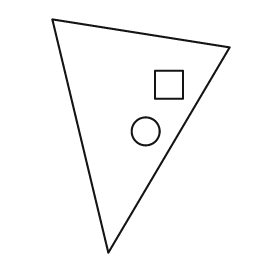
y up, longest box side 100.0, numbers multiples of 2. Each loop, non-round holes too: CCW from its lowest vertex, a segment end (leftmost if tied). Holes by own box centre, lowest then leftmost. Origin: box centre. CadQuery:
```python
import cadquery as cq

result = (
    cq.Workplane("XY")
    .moveTo(-14.0, -50.0)
    .lineTo(38.0, 38.0)
    .lineTo(-38.0, 50.0)
    .close()
    .moveTo(2.0, 2.0)
    .circle(6.0)
    .moveTo(6.0, 16.0)
    .lineTo(18.0, 16.0)
    .lineTo(18.0, 28.0)
    .lineTo(6.0, 28.0)
    .close()
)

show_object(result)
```